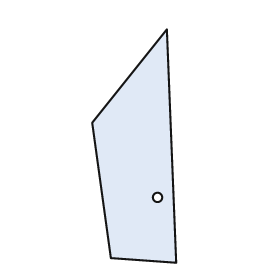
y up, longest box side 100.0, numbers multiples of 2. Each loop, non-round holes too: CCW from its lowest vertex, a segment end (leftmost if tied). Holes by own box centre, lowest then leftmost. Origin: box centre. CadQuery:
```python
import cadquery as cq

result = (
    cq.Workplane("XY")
    .moveTo(18.0, -50.0)
    .lineTo(14.0, 50.0)
    .lineTo(-18.0, 10.0)
    .lineTo(-10.0, -48.0)
    .close()
    .moveTo(10.0, -22.0)
    .circle(2.0)
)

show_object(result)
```